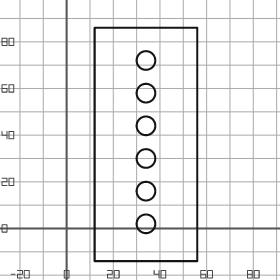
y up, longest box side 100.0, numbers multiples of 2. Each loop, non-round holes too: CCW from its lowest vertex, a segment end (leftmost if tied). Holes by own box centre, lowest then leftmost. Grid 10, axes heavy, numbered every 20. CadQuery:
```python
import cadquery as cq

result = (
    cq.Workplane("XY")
    .moveTo(12.0, -14.0)
    .lineTo(56.0, -14.0)
    .lineTo(56.0, 86.0)
    .lineTo(12.0, 86.0)
    .close()
    .moveTo(34.0, 2.0)
    .circle(4.0)
    .moveTo(34.0, 16.0)
    .circle(4.0)
    .moveTo(34.0, 30.0)
    .circle(4.0)
    .moveTo(34.0, 44.0)
    .circle(4.0)
    .moveTo(34.0, 58.0)
    .circle(4.0)
    .moveTo(34.0, 72.0)
    .circle(4.0)
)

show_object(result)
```